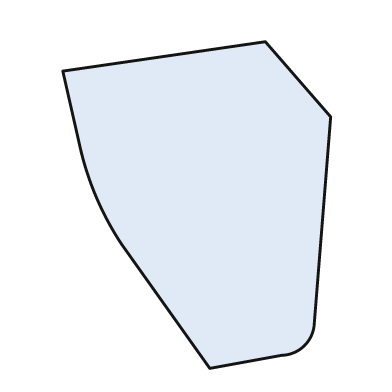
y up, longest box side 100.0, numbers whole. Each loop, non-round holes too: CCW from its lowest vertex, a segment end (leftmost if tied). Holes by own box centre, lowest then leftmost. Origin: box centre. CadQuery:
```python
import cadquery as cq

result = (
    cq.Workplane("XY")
    .moveTo(4.0, -50.0)
    .lineTo(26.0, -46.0)
    .threePointArc((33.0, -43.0), (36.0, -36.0))
    .lineTo(41.0, 27.0)
    .lineTo(21.0, 50.0)
    .lineTo(-41.0, 41.0)
    .lineTo(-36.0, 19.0)
    .threePointArc((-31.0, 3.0), (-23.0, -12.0))
    .close()
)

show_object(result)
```